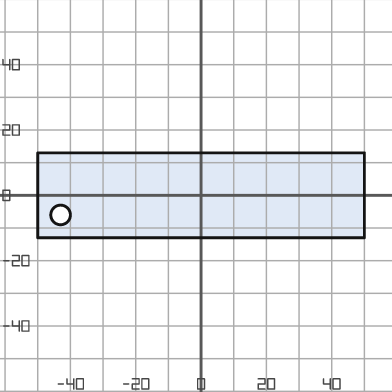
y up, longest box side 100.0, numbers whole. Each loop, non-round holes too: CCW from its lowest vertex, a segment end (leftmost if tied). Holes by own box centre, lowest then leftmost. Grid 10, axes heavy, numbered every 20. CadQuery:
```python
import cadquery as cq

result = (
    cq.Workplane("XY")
    .moveTo(-50.0, -13.0)
    .lineTo(50.0, -13.0)
    .lineTo(50.0, 13.0)
    .lineTo(-50.0, 13.0)
    .close()
    .moveTo(-43.0, -6.0)
    .circle(3.0)
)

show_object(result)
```